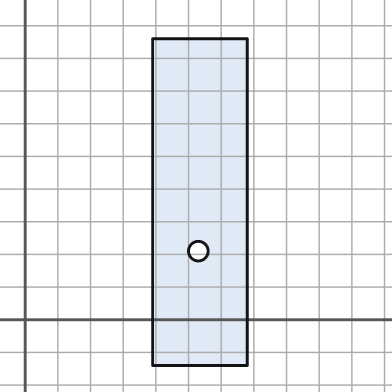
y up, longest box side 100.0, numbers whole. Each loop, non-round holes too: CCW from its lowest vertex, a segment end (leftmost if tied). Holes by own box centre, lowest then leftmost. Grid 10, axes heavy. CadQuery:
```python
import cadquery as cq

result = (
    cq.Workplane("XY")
    .moveTo(39.0, -14.0)
    .lineTo(68.0, -14.0)
    .lineTo(68.0, 86.0)
    .lineTo(39.0, 86.0)
    .close()
    .moveTo(53.0, 21.0)
    .circle(3.0)
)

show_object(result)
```